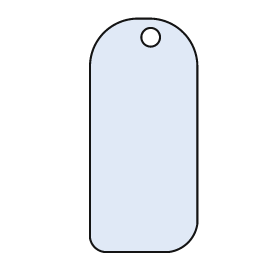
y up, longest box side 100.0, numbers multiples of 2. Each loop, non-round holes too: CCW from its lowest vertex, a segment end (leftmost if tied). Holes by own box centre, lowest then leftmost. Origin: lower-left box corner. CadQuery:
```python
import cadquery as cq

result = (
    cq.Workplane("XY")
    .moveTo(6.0, 0.0)
    .lineTo(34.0, 0.0)
    .threePointArc((42.0, 4.0), (46.0, 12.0))
    .lineTo(46.0, 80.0)
    .threePointArc((40.0, 94.0), (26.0, 100.0))
    .lineTo(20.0, 100.0)
    .threePointArc((6.0, 94.0), (0.0, 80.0))
    .lineTo(0.0, 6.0)
    .threePointArc((2.0, 2.0), (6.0, 0.0))
    .close()
    .moveTo(26.0, 92.0)
    .circle(4.0)
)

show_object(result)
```